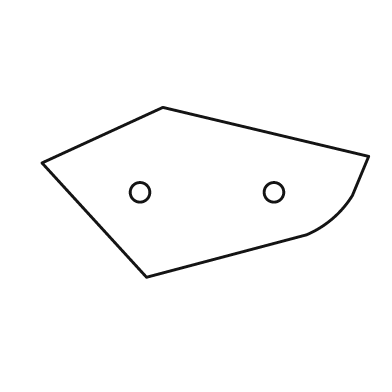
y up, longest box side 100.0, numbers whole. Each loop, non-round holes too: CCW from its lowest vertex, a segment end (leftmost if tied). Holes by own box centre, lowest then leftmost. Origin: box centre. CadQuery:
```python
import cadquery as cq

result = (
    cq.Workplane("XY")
    .moveTo(-18.0, -26.0)
    .lineTo(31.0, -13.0)
    .threePointArc((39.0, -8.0), (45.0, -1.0))
    .lineTo(50.0, 11.0)
    .lineTo(-13.0, 26.0)
    .lineTo(-50.0, 9.0)
    .close()
    .moveTo(-20.0, 0.0)
    .circle(3.0)
    .moveTo(21.0, 0.0)
    .circle(3.0)
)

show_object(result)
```